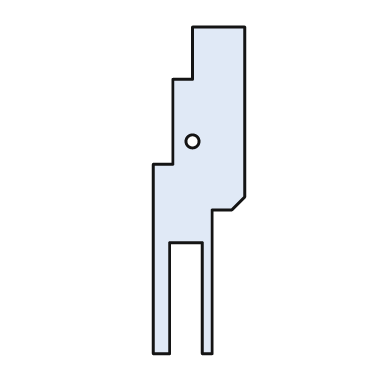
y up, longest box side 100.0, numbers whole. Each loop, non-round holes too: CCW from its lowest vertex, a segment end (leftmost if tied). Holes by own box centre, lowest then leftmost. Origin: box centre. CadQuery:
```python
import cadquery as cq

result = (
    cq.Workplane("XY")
    .moveTo(-14.0, -50.0)
    .lineTo(-9.0, -50.0)
    .lineTo(-9.0, -16.0)
    .lineTo(1.0, -16.0)
    .lineTo(1.0, -50.0)
    .lineTo(4.0, -50.0)
    .lineTo(4.0, -6.0)
    .lineTo(10.0, -6.0)
    .lineTo(14.0, -2.0)
    .lineTo(14.0, 50.0)
    .lineTo(-2.0, 50.0)
    .lineTo(-2.0, 34.0)
    .lineTo(-8.0, 34.0)
    .lineTo(-8.0, 8.0)
    .lineTo(-14.0, 8.0)
    .close()
    .moveTo(-2.0, 15.0)
    .circle(2.0)
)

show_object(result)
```